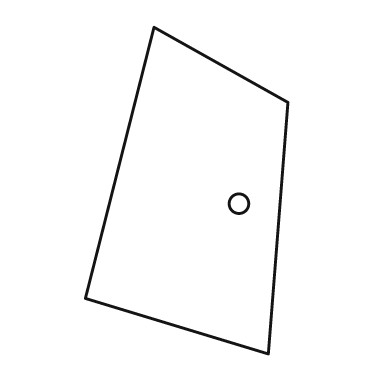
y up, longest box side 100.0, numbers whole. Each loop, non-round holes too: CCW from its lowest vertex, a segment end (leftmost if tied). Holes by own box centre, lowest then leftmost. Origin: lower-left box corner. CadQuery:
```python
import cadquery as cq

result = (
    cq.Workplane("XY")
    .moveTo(56.0, 0.0)
    .lineTo(62.0, 77.0)
    .lineTo(21.0, 100.0)
    .lineTo(0.0, 17.0)
    .close()
    .moveTo(47.0, 46.0)
    .circle(3.0)
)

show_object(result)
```